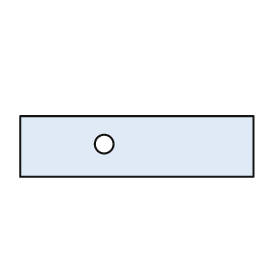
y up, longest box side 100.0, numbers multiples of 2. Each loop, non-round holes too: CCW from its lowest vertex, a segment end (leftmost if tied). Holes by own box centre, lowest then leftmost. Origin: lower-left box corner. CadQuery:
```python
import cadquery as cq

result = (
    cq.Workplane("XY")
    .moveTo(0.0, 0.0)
    .lineTo(100.0, 0.0)
    .lineTo(100.0, 26.0)
    .lineTo(0.0, 26.0)
    .close()
    .moveTo(36.0, 14.0)
    .circle(4.0)
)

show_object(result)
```